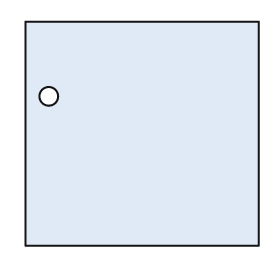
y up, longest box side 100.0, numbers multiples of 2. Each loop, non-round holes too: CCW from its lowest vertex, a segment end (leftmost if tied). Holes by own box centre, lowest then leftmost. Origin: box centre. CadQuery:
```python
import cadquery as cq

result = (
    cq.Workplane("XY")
    .moveTo(-50.0, -48.0)
    .lineTo(50.0, -48.0)
    .lineTo(50.0, 48.0)
    .lineTo(-50.0, 48.0)
    .close()
    .moveTo(-40.0, 16.0)
    .circle(4.0)
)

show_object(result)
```